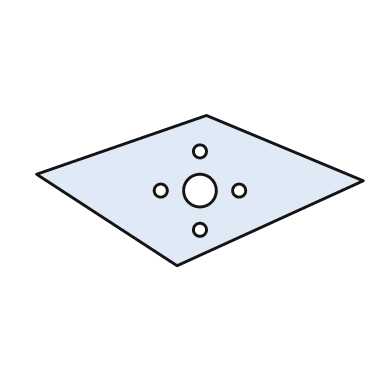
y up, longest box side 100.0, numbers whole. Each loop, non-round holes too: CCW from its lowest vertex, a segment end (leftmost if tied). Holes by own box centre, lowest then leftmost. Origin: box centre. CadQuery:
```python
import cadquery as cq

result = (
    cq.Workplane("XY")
    .moveTo(-7.0, -23.0)
    .lineTo(50.0, 3.0)
    .lineTo(2.0, 23.0)
    .lineTo(-50.0, 5.0)
    .close()
    .moveTo(0.0, -12.0)
    .circle(2.0)
    .moveTo(-12.0, 0.0)
    .circle(2.0)
    .moveTo(0.0, 0.0)
    .circle(5.0)
    .moveTo(12.0, 0.0)
    .circle(2.0)
    .moveTo(0.0, 12.0)
    .circle(2.0)
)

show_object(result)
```